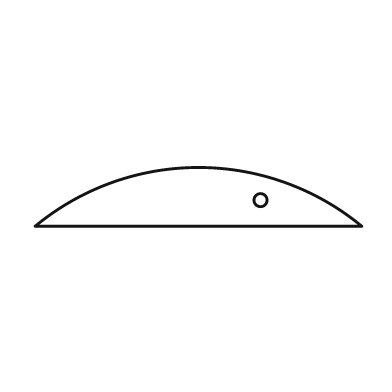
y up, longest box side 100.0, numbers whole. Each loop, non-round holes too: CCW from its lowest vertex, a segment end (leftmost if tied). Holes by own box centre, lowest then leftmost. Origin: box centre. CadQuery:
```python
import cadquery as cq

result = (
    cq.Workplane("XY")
    .moveTo(-50.0, -9.0)
    .lineTo(50.0, -9.0)
    .threePointArc((0.0, 9.0), (-50.0, -9.0))
    .close()
    .moveTo(19.0, -1.0)
    .circle(2.0)
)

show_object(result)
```